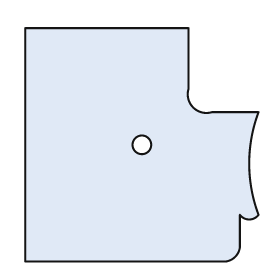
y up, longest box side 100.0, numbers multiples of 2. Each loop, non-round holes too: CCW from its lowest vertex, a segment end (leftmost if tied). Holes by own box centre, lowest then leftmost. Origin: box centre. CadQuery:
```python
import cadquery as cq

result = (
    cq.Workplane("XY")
    .moveTo(-50.0, -50.0)
    .lineTo(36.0, -50.0)
    .threePointArc((40.0, -48.0), (42.0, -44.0))
    .lineTo(42.0, -30.0)
    .threePointArc((46.0, -32.0), (50.0, -30.0))
    .threePointArc((46.0, -8.0), (50.0, 14.0))
    .lineTo(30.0, 14.0)
    .threePointArc((22.0, 16.0), (20.0, 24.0))
    .lineTo(20.0, 50.0)
    .lineTo(-50.0, 50.0)
    .close()
    .moveTo(0.0, 0.0)
    .circle(4.0)
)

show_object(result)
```